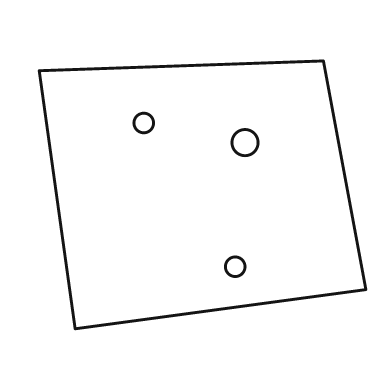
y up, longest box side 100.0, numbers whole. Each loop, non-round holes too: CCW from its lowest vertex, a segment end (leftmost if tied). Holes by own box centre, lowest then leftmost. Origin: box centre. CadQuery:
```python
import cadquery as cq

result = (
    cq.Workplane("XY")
    .moveTo(-39.0, -41.0)
    .lineTo(50.0, -29.0)
    .lineTo(37.0, 41.0)
    .lineTo(-50.0, 38.0)
    .close()
    .moveTo(10.0, -22.0)
    .circle(3.0)
    .moveTo(13.0, 16.0)
    .circle(4.0)
    .moveTo(-18.0, 22.0)
    .circle(3.0)
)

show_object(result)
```